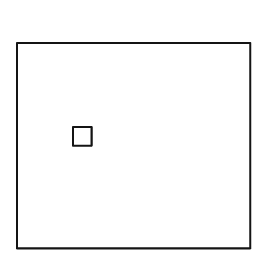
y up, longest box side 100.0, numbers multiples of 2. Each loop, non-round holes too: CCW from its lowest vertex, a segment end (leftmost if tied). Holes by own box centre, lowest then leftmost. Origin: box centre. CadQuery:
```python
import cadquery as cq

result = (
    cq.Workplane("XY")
    .moveTo(-50.0, -44.0)
    .lineTo(50.0, -44.0)
    .lineTo(50.0, 44.0)
    .lineTo(-50.0, 44.0)
    .close()
    .moveTo(-26.0, 0.0)
    .lineTo(-18.0, 0.0)
    .lineTo(-18.0, 8.0)
    .lineTo(-26.0, 8.0)
    .close()
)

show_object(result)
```